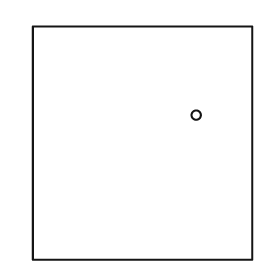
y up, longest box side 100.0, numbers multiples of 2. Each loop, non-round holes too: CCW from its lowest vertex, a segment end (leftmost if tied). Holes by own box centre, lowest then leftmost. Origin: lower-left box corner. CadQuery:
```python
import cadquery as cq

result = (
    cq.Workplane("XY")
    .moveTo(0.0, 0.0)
    .lineTo(94.0, 0.0)
    .lineTo(94.0, 100.0)
    .lineTo(0.0, 100.0)
    .close()
    .moveTo(70.0, 62.0)
    .circle(2.0)
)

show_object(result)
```